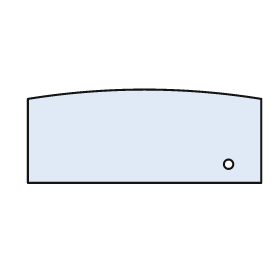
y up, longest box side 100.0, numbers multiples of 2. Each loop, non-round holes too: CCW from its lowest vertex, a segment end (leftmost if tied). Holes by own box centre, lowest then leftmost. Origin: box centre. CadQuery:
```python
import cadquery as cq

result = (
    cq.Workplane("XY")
    .moveTo(-50.0, -20.0)
    .lineTo(50.0, -20.0)
    .lineTo(50.0, 16.0)
    .threePointArc((0.0, 20.0), (-50.0, 16.0))
    .close()
    .moveTo(36.0, -12.0)
    .circle(2.0)
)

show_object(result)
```